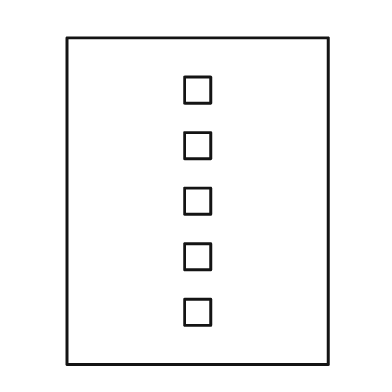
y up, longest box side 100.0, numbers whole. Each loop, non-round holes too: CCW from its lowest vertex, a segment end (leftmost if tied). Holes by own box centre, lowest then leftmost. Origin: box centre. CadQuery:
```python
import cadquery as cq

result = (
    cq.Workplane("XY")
    .moveTo(-40.0, -50.0)
    .lineTo(40.0, -50.0)
    .lineTo(40.0, 50.0)
    .lineTo(-40.0, 50.0)
    .close()
    .moveTo(-4.0, -38.0)
    .lineTo(4.0, -38.0)
    .lineTo(4.0, -30.0)
    .lineTo(-4.0, -30.0)
    .close()
    .moveTo(-4.0, -21.0)
    .lineTo(4.0, -21.0)
    .lineTo(4.0, -13.0)
    .lineTo(-4.0, -13.0)
    .close()
    .moveTo(-4.0, -4.0)
    .lineTo(4.0, -4.0)
    .lineTo(4.0, 4.0)
    .lineTo(-4.0, 4.0)
    .close()
    .moveTo(-4.0, 13.0)
    .lineTo(4.0, 13.0)
    .lineTo(4.0, 21.0)
    .lineTo(-4.0, 21.0)
    .close()
    .moveTo(-4.0, 30.0)
    .lineTo(4.0, 30.0)
    .lineTo(4.0, 38.0)
    .lineTo(-4.0, 38.0)
    .close()
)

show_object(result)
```